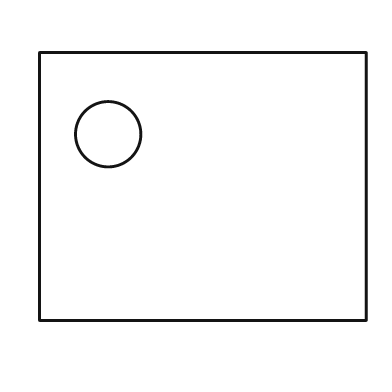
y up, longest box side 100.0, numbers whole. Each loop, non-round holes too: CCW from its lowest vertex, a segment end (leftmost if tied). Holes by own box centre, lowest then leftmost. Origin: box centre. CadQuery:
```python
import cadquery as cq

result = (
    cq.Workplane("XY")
    .moveTo(-50.0, -41.0)
    .lineTo(50.0, -41.0)
    .lineTo(50.0, 41.0)
    .lineTo(-50.0, 41.0)
    .close()
    .moveTo(-29.0, 16.0)
    .circle(10.0)
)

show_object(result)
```